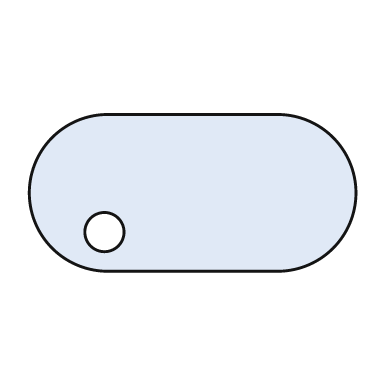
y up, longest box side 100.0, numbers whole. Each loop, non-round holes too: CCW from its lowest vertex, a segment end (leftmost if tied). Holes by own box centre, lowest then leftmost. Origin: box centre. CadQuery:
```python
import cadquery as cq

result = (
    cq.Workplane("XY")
    .moveTo(-26.0, -24.0)
    .lineTo(26.0, -24.0)
    .threePointArc((50.0, 0.0), (26.0, 24.0))
    .lineTo(-26.0, 24.0)
    .threePointArc((-50.0, 0.0), (-26.0, -24.0))
    .close()
    .moveTo(-27.0, -12.0)
    .circle(6.0)
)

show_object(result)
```